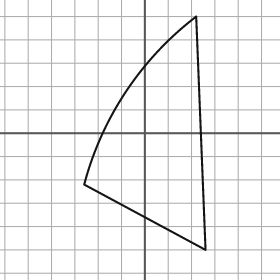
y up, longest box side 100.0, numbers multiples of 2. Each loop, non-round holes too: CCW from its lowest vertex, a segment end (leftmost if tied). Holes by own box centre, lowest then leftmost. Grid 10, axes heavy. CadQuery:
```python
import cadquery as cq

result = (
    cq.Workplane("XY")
    .moveTo(26.0, -50.0)
    .lineTo(22.0, 50.0)
    .threePointArc((-8.0, 18.0), (-26.0, -22.0))
    .close()
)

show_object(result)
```